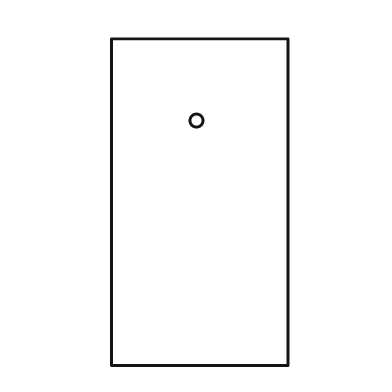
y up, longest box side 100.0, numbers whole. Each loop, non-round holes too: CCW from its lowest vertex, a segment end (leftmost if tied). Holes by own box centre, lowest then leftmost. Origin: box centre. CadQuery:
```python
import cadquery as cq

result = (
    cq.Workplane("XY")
    .moveTo(-27.0, -50.0)
    .lineTo(27.0, -50.0)
    .lineTo(27.0, 50.0)
    .lineTo(-27.0, 50.0)
    .close()
    .moveTo(-1.0, 25.0)
    .circle(2.0)
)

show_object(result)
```